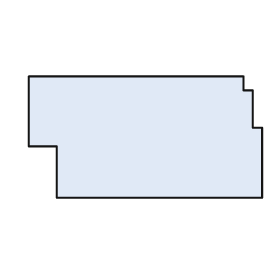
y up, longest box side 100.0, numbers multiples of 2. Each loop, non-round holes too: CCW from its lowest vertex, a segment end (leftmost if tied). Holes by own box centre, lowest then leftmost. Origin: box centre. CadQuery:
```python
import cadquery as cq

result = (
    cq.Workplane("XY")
    .moveTo(-38.0, -26.0)
    .lineTo(50.0, -26.0)
    .lineTo(50.0, 4.0)
    .lineTo(46.0, 4.0)
    .lineTo(46.0, 20.0)
    .lineTo(42.0, 20.0)
    .lineTo(42.0, 26.0)
    .lineTo(-50.0, 26.0)
    .lineTo(-50.0, -4.0)
    .lineTo(-38.0, -4.0)
    .close()
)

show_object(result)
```